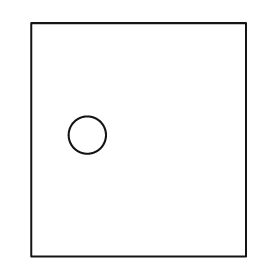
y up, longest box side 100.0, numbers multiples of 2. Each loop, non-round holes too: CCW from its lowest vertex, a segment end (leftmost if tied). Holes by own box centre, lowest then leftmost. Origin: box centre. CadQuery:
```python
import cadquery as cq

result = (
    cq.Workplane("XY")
    .moveTo(-46.0, -50.0)
    .lineTo(46.0, -50.0)
    .lineTo(46.0, 50.0)
    .lineTo(-46.0, 50.0)
    .close()
    .moveTo(-22.0, 2.0)
    .circle(8.0)
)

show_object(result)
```